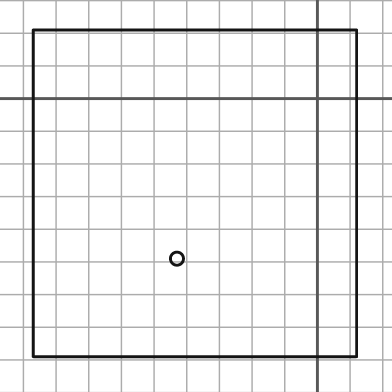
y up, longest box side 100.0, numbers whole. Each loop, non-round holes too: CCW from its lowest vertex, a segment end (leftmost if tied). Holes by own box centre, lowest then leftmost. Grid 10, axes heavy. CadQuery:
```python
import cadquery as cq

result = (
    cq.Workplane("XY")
    .moveTo(-87.0, -79.0)
    .lineTo(12.0, -79.0)
    .lineTo(12.0, 21.0)
    .lineTo(-87.0, 21.0)
    .close()
    .moveTo(-43.0, -49.0)
    .circle(2.0)
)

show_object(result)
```